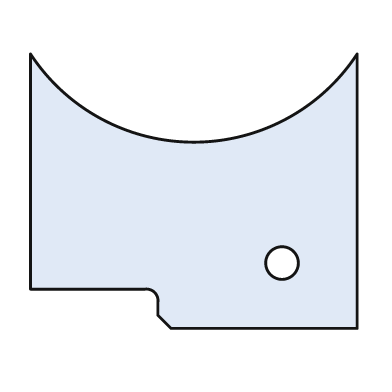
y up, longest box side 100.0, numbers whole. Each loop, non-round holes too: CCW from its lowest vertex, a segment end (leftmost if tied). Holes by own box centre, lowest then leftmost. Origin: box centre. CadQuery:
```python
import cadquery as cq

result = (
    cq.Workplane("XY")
    .moveTo(-7.0, -42.0)
    .lineTo(50.0, -42.0)
    .lineTo(50.0, 42.0)
    .threePointArc((0.0, 15.0), (-50.0, 42.0))
    .lineTo(-50.0, -30.0)
    .lineTo(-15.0, -30.0)
    .threePointArc((-12.0, -31.0), (-11.0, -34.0))
    .lineTo(-11.0, -38.0)
    .close()
    .moveTo(27.0, -22.0)
    .circle(5.0)
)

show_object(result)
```